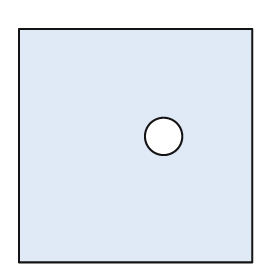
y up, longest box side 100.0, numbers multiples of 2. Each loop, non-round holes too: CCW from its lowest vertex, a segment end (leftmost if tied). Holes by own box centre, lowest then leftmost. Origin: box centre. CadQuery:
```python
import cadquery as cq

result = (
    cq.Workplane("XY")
    .moveTo(-50.0, -50.0)
    .lineTo(50.0, -50.0)
    .lineTo(50.0, 50.0)
    .lineTo(-50.0, 50.0)
    .close()
    .moveTo(12.0, 4.0)
    .circle(8.0)
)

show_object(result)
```